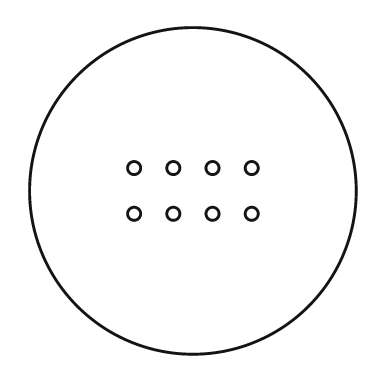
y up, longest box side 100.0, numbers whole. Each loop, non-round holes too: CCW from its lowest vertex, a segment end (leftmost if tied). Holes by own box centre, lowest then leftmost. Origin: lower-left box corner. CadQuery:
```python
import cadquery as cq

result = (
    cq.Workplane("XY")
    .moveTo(50.0, 50.0)
    .circle(50.0)
    .moveTo(32.0, 43.0)
    .circle(2.0)
    .moveTo(44.0, 43.0)
    .circle(2.0)
    .moveTo(56.0, 43.0)
    .circle(2.0)
    .moveTo(68.0, 43.0)
    .circle(2.0)
    .moveTo(32.0, 57.0)
    .circle(2.0)
    .moveTo(44.0, 57.0)
    .circle(2.0)
    .moveTo(56.0, 57.0)
    .circle(2.0)
    .moveTo(68.0, 57.0)
    .circle(2.0)
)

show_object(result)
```